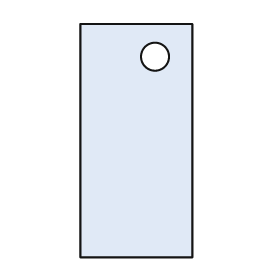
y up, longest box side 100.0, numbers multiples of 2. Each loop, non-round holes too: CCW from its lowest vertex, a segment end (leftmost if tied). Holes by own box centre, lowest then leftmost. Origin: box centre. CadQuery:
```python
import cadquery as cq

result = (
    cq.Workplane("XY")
    .moveTo(-24.0, -50.0)
    .lineTo(24.0, -50.0)
    .lineTo(24.0, 50.0)
    .lineTo(-24.0, 50.0)
    .close()
    .moveTo(8.0, 36.0)
    .circle(6.0)
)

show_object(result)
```